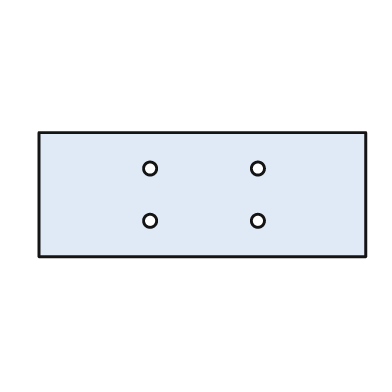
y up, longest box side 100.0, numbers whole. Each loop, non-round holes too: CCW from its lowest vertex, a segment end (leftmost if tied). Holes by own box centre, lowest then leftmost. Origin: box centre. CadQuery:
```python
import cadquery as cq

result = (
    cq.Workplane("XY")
    .moveTo(-50.0, -19.0)
    .lineTo(50.0, -19.0)
    .lineTo(50.0, 19.0)
    .lineTo(-50.0, 19.0)
    .close()
    .moveTo(-16.0, -8.0)
    .circle(2.0)
    .moveTo(17.0, -8.0)
    .circle(2.0)
    .moveTo(-16.0, 8.0)
    .circle(2.0)
    .moveTo(17.0, 8.0)
    .circle(2.0)
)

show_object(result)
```